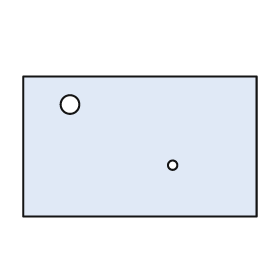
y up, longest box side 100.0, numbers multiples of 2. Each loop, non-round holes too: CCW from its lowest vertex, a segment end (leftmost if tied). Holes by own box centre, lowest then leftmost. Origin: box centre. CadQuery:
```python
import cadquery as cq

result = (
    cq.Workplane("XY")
    .moveTo(-50.0, -30.0)
    .lineTo(50.0, -30.0)
    .lineTo(50.0, 30.0)
    .lineTo(-50.0, 30.0)
    .close()
    .moveTo(14.0, -8.0)
    .circle(2.0)
    .moveTo(-30.0, 18.0)
    .circle(4.0)
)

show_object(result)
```